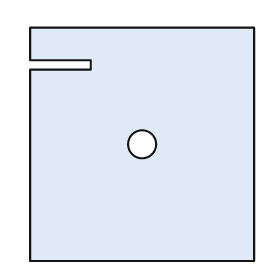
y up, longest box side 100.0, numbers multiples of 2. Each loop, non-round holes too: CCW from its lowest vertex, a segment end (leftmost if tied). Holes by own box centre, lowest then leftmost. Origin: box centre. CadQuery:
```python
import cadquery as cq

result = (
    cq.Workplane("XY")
    .moveTo(-48.0, -50.0)
    .lineTo(48.0, -50.0)
    .lineTo(48.0, 50.0)
    .lineTo(-48.0, 50.0)
    .lineTo(-48.0, 36.0)
    .lineTo(-22.0, 36.0)
    .lineTo(-22.0, 32.0)
    .lineTo(-48.0, 32.0)
    .close()
    .moveTo(0.0, 0.0)
    .circle(6.0)
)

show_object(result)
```